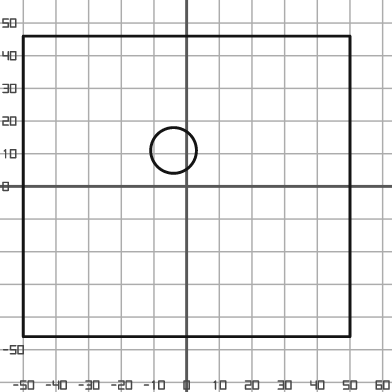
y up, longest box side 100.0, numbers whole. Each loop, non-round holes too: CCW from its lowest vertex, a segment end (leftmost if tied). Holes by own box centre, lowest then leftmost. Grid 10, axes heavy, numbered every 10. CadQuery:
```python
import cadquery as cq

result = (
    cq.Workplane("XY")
    .moveTo(-50.0, -46.0)
    .lineTo(50.0, -46.0)
    .lineTo(50.0, 46.0)
    .lineTo(-50.0, 46.0)
    .close()
    .moveTo(-4.0, 11.0)
    .circle(7.0)
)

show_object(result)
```